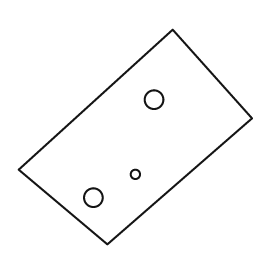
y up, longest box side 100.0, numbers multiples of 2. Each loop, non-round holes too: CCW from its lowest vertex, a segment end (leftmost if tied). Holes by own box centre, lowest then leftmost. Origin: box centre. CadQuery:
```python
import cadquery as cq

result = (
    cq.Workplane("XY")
    .moveTo(-12.0, -46.0)
    .lineTo(50.0, 8.0)
    .lineTo(16.0, 46.0)
    .lineTo(-50.0, -14.0)
    .close()
    .moveTo(-18.0, -26.0)
    .circle(4.0)
    .moveTo(0.0, -16.0)
    .circle(2.0)
    .moveTo(8.0, 16.0)
    .circle(4.0)
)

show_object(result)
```